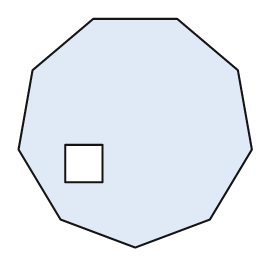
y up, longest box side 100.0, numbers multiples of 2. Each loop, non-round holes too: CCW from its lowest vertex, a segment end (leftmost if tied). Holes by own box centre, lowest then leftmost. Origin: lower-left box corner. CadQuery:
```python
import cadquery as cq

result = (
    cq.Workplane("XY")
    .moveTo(50.0, 0.0)
    .lineTo(82.0, 12.0)
    .lineTo(100.0, 42.0)
    .lineTo(94.0, 76.0)
    .lineTo(68.0, 98.0)
    .lineTo(32.0, 98.0)
    .lineTo(6.0, 76.0)
    .lineTo(0.0, 42.0)
    .lineTo(18.0, 12.0)
    .close()
    .moveTo(20.0, 28.0)
    .lineTo(36.0, 28.0)
    .lineTo(36.0, 44.0)
    .lineTo(20.0, 44.0)
    .close()
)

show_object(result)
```